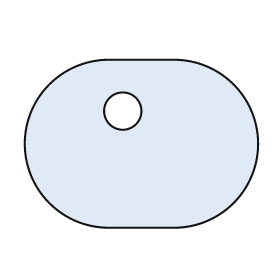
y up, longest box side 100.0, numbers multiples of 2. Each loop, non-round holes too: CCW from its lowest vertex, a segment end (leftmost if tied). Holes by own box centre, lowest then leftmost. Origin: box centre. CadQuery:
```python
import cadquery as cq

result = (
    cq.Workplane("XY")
    .moveTo(-14.0, -36.0)
    .lineTo(14.0, -36.0)
    .threePointArc((50.0, 0.0), (14.0, 36.0))
    .lineTo(-14.0, 36.0)
    .threePointArc((-50.0, 0.0), (-14.0, -36.0))
    .close()
    .moveTo(-8.0, 14.0)
    .circle(8.0)
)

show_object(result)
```